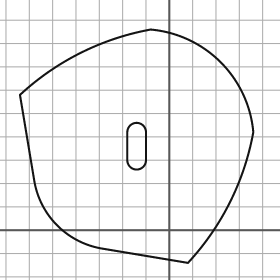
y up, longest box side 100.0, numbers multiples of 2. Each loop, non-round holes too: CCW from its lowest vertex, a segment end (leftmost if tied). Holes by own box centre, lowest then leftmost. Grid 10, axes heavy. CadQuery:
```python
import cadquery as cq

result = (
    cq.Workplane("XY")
    .moveTo(8.0, -14.0)
    .threePointArc((26.0, 12.0), (36.0, 42.0))
    .threePointArc((22.0, 72.0), (-8.0, 86.0))
    .threePointArc((-38.0, 76.0), (-64.0, 58.0))
    .lineTo(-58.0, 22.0)
    .threePointArc((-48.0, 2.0), (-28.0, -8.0))
    .close()
    .moveTo(-18.0, 30.0)
    .threePointArc((-14.0, 26.0), (-10.0, 30.0))
    .lineTo(-10.0, 42.0)
    .threePointArc((-14.0, 46.0), (-18.0, 42.0))
    .close()
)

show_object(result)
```